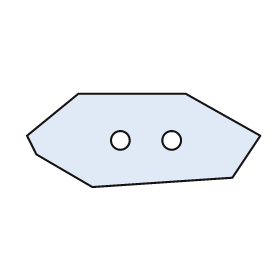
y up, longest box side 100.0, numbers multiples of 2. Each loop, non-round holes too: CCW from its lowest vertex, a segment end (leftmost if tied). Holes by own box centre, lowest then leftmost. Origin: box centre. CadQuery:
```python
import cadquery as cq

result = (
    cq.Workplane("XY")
    .moveTo(-22.0, -20.0)
    .lineTo(38.0, -16.0)
    .lineTo(50.0, 2.0)
    .lineTo(18.0, 20.0)
    .lineTo(-28.0, 20.0)
    .lineTo(-50.0, 2.0)
    .lineTo(-46.0, -6.0)
    .close()
    .moveTo(-10.0, 0.0)
    .circle(4.0)
    .moveTo(12.0, 0.0)
    .circle(4.0)
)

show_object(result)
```